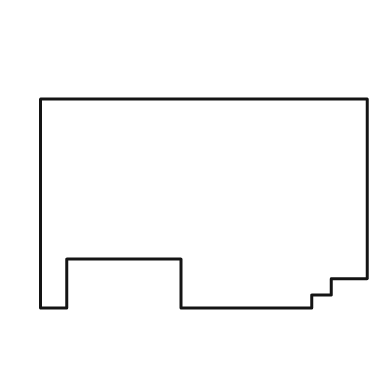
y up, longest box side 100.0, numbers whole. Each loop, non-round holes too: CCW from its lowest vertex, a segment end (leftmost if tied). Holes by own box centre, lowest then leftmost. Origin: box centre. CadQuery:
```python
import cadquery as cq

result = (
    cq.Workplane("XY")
    .moveTo(-50.0, -32.0)
    .lineTo(-42.0, -32.0)
    .lineTo(-42.0, -17.0)
    .lineTo(-7.0, -17.0)
    .lineTo(-7.0, -32.0)
    .lineTo(33.0, -32.0)
    .lineTo(33.0, -28.0)
    .lineTo(39.0, -28.0)
    .lineTo(39.0, -23.0)
    .lineTo(50.0, -23.0)
    .lineTo(50.0, 32.0)
    .lineTo(-50.0, 32.0)
    .close()
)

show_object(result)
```